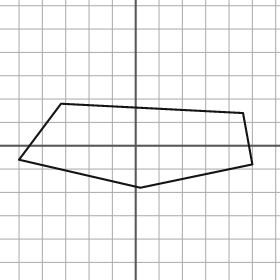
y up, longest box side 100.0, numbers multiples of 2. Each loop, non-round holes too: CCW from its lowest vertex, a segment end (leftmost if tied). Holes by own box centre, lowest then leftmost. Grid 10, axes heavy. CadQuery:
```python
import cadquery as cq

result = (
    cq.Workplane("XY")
    .moveTo(2.0, -18.0)
    .lineTo(50.0, -8.0)
    .lineTo(46.0, 14.0)
    .lineTo(-32.0, 18.0)
    .lineTo(-50.0, -6.0)
    .close()
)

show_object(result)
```